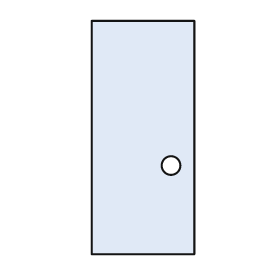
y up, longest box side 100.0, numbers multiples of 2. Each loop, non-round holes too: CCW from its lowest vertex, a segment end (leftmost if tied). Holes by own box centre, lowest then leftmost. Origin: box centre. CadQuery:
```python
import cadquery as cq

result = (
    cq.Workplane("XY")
    .moveTo(-22.0, -50.0)
    .lineTo(22.0, -50.0)
    .lineTo(22.0, 50.0)
    .lineTo(-22.0, 50.0)
    .close()
    .moveTo(12.0, -12.0)
    .circle(4.0)
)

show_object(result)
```